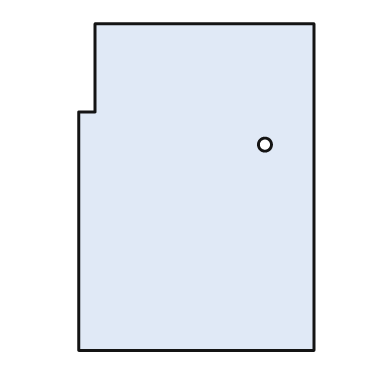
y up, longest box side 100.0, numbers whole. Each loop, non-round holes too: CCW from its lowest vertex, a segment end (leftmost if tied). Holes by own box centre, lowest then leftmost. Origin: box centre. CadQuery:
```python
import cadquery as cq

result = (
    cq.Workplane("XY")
    .moveTo(-36.0, -50.0)
    .lineTo(36.0, -50.0)
    .lineTo(36.0, 50.0)
    .lineTo(-31.0, 50.0)
    .lineTo(-31.0, 23.0)
    .lineTo(-36.0, 23.0)
    .close()
    .moveTo(21.0, 13.0)
    .circle(2.0)
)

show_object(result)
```